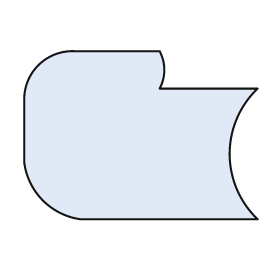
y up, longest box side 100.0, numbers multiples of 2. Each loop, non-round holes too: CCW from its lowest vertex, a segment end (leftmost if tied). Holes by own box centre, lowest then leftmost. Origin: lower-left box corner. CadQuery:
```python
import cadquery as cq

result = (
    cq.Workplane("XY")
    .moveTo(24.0, 0.0)
    .lineTo(100.0, 0.0)
    .threePointArc((88.0, 28.0), (100.0, 56.0))
    .lineTo(58.0, 56.0)
    .threePointArc((60.0, 64.0), (58.0, 72.0))
    .lineTo(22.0, 72.0)
    .threePointArc((6.0, 66.0), (0.0, 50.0))
    .lineTo(0.0, 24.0)
    .threePointArc((8.0, 8.0), (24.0, 0.0))
    .close()
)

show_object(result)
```